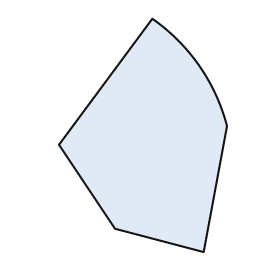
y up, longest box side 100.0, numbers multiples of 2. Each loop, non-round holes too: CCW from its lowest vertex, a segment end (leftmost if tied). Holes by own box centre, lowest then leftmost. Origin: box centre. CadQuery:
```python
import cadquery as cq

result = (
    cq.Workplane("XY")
    .moveTo(26.0, -50.0)
    .lineTo(36.0, 4.0)
    .threePointArc((24.0, 30.0), (4.0, 50.0))
    .lineTo(-36.0, -4.0)
    .lineTo(-12.0, -40.0)
    .close()
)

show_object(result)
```